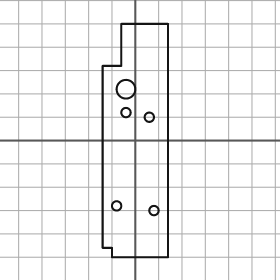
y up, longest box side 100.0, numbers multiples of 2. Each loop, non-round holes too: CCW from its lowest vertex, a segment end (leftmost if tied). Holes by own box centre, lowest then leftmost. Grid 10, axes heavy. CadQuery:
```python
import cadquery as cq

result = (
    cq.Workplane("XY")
    .moveTo(-10.0, -50.0)
    .lineTo(14.0, -50.0)
    .lineTo(14.0, 50.0)
    .lineTo(-6.0, 50.0)
    .lineTo(-6.0, 32.0)
    .lineTo(-14.0, 32.0)
    .lineTo(-14.0, -46.0)
    .lineTo(-10.0, -46.0)
    .close()
    .moveTo(8.0, -30.0)
    .circle(2.0)
    .moveTo(-8.0, -28.0)
    .circle(2.0)
    .moveTo(6.0, 10.0)
    .circle(2.0)
    .moveTo(-4.0, 12.0)
    .circle(2.0)
    .moveTo(-4.0, 22.0)
    .circle(4.0)
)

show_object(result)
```